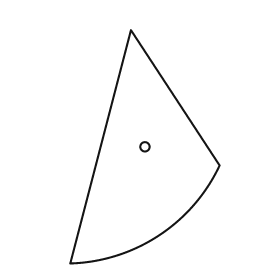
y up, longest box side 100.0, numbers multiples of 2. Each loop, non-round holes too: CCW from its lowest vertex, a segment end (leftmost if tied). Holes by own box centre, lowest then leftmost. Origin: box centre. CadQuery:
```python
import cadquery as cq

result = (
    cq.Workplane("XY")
    .moveTo(-32.0, -50.0)
    .threePointArc((6.0, -38.0), (32.0, -8.0))
    .lineTo(-6.0, 50.0)
    .close()
    .moveTo(0.0, 0.0)
    .circle(2.0)
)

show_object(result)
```